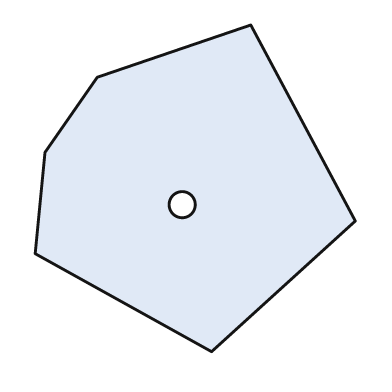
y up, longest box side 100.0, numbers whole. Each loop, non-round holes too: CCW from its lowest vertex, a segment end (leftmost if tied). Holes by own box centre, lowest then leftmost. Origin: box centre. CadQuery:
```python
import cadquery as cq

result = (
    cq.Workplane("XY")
    .moveTo(5.0, -50.0)
    .lineTo(49.0, -10.0)
    .lineTo(17.0, 50.0)
    .lineTo(-30.0, 34.0)
    .lineTo(-46.0, 11.0)
    .lineTo(-49.0, -20.0)
    .close()
    .moveTo(-4.0, -5.0)
    .circle(4.0)
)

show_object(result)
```